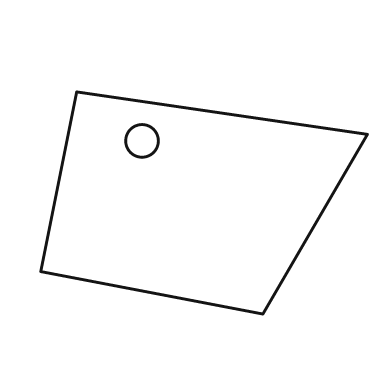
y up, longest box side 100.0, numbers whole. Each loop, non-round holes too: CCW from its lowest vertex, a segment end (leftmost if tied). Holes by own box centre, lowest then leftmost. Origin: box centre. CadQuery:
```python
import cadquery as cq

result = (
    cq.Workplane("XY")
    .moveTo(18.0, -34.0)
    .lineTo(50.0, 21.0)
    .lineTo(-39.0, 34.0)
    .lineTo(-50.0, -21.0)
    .close()
    .moveTo(-19.0, 19.0)
    .circle(5.0)
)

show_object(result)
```